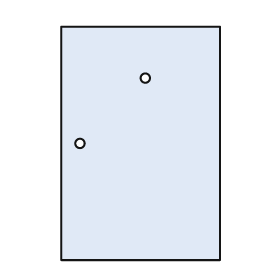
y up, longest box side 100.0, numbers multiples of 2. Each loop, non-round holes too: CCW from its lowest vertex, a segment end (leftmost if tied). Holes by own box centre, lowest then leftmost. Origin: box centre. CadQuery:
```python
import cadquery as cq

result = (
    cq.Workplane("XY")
    .moveTo(-34.0, -50.0)
    .lineTo(34.0, -50.0)
    .lineTo(34.0, 50.0)
    .lineTo(-34.0, 50.0)
    .close()
    .moveTo(-26.0, 0.0)
    .circle(2.0)
    .moveTo(2.0, 28.0)
    .circle(2.0)
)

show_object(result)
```